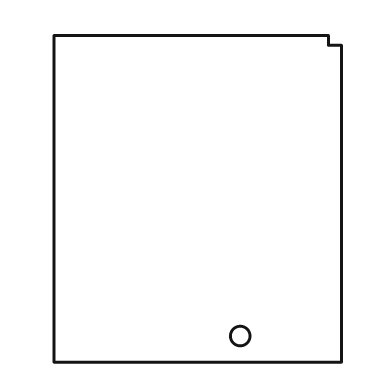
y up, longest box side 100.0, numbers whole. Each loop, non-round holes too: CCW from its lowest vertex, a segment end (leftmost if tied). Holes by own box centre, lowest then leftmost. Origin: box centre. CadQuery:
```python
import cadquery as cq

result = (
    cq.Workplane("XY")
    .moveTo(-44.0, -50.0)
    .lineTo(44.0, -50.0)
    .lineTo(44.0, 47.0)
    .lineTo(40.0, 47.0)
    .lineTo(40.0, 50.0)
    .lineTo(-44.0, 50.0)
    .close()
    .moveTo(13.0, -42.0)
    .circle(3.0)
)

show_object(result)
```